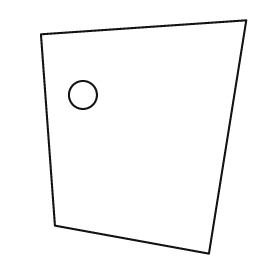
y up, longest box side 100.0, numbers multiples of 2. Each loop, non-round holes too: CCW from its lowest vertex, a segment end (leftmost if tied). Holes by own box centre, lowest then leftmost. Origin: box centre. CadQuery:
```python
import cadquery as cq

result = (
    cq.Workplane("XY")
    .moveTo(28.0, -50.0)
    .lineTo(44.0, 50.0)
    .lineTo(-44.0, 44.0)
    .lineTo(-38.0, -38.0)
    .close()
    .moveTo(-26.0, 18.0)
    .circle(6.0)
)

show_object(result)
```